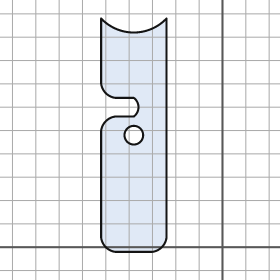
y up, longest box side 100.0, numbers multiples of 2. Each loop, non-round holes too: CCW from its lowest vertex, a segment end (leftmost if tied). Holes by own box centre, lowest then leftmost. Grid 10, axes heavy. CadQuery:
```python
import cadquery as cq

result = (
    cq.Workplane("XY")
    .moveTo(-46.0, -2.0)
    .lineTo(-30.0, -2.0)
    .threePointArc((-26.0, 0.0), (-24.0, 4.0))
    .lineTo(-24.0, 98.0)
    .threePointArc((-38.0, 92.0), (-52.0, 98.0))
    .lineTo(-52.0, 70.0)
    .threePointArc((-50.0, 66.0), (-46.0, 64.0))
    .lineTo(-38.0, 64.0)
    .threePointArc((-36.0, 60.0), (-38.0, 56.0))
    .lineTo(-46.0, 56.0)
    .threePointArc((-50.0, 54.0), (-52.0, 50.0))
    .lineTo(-52.0, 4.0)
    .threePointArc((-50.0, 0.0), (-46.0, -2.0))
    .close()
    .moveTo(-38.0, 48.0)
    .circle(4.0)
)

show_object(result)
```